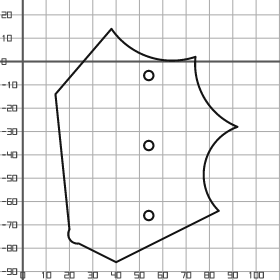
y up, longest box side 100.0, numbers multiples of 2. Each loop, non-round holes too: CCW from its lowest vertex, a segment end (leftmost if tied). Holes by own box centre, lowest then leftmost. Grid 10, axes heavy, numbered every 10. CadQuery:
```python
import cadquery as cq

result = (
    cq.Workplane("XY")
    .moveTo(40.0, -86.0)
    .lineTo(84.0, -64.0)
    .threePointArc((78.0, -44.0), (92.0, -28.0))
    .threePointArc((78.0, -16.0), (74.0, 2.0))
    .threePointArc((54.0, 2.0), (38.0, 14.0))
    .lineTo(14.0, -14.0)
    .lineTo(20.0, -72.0)
    .threePointArc((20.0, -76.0), (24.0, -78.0))
    .close()
    .moveTo(54.0, -66.0)
    .circle(2.0)
    .moveTo(54.0, -36.0)
    .circle(2.0)
    .moveTo(54.0, -6.0)
    .circle(2.0)
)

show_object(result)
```